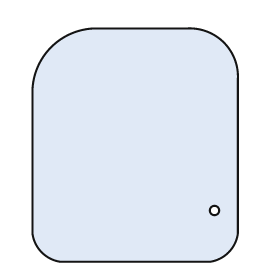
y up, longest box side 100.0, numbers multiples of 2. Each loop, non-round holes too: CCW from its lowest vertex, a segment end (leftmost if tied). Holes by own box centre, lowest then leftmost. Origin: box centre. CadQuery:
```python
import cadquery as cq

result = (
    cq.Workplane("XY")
    .moveTo(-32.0, -50.0)
    .lineTo(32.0, -50.0)
    .threePointArc((40.0, -46.0), (44.0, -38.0))
    .lineTo(44.0, 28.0)
    .threePointArc((38.0, 44.0), (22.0, 50.0))
    .lineTo(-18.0, 50.0)
    .threePointArc((-36.0, 42.0), (-44.0, 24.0))
    .lineTo(-44.0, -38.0)
    .threePointArc((-40.0, -46.0), (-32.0, -50.0))
    .close()
    .moveTo(34.0, -28.0)
    .circle(2.0)
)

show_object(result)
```